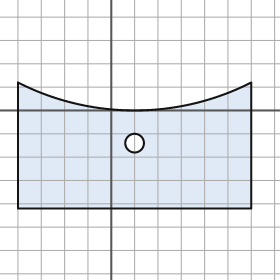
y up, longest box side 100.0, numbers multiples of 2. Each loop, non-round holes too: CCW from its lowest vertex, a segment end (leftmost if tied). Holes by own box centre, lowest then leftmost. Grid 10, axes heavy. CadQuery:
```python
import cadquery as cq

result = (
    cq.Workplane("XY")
    .moveTo(-40.0, -42.0)
    .lineTo(60.0, -42.0)
    .lineTo(60.0, 12.0)
    .threePointArc((10.0, 0.0), (-40.0, 12.0))
    .close()
    .moveTo(10.0, -14.0)
    .circle(4.0)
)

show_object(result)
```